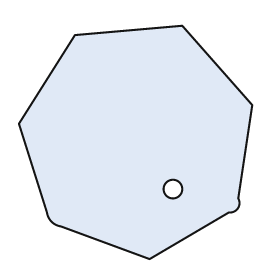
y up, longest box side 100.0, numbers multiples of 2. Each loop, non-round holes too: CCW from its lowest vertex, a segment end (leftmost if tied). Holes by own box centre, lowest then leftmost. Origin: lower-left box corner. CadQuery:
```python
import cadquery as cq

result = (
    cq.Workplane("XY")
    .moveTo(56.0, 0.0)
    .lineTo(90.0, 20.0)
    .threePointArc((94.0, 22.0), (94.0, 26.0))
    .lineTo(100.0, 66.0)
    .lineTo(70.0, 100.0)
    .lineTo(24.0, 96.0)
    .lineTo(0.0, 58.0)
    .lineTo(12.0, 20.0)
    .threePointArc((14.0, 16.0), (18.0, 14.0))
    .close()
    .moveTo(66.0, 30.0)
    .circle(4.0)
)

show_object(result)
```